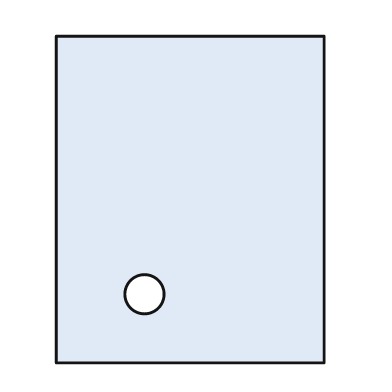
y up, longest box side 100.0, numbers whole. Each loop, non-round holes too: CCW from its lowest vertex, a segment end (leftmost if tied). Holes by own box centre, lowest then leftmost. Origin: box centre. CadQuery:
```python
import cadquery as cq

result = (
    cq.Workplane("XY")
    .moveTo(-41.0, -50.0)
    .lineTo(41.0, -50.0)
    .lineTo(41.0, 50.0)
    .lineTo(-41.0, 50.0)
    .close()
    .moveTo(-14.0, -29.0)
    .circle(6.0)
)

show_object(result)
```